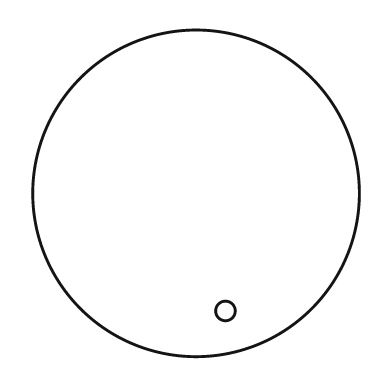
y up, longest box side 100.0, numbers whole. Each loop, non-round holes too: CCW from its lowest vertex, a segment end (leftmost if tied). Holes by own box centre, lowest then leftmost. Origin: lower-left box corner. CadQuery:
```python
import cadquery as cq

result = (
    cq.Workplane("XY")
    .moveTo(50.0, 50.0)
    .circle(50.0)
    .moveTo(59.0, 14.0)
    .circle(3.0)
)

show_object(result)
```